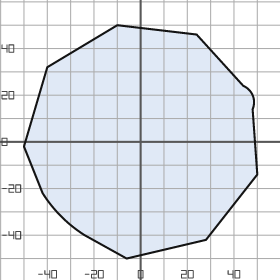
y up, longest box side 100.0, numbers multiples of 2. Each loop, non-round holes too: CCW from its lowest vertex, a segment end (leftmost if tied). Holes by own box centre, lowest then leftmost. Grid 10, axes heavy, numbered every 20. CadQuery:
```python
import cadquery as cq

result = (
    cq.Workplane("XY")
    .moveTo(-6.0, -50.0)
    .lineTo(28.0, -42.0)
    .lineTo(50.0, -14.0)
    .lineTo(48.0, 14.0)
    .threePointArc((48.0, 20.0), (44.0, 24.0))
    .lineTo(24.0, 46.0)
    .lineTo(-10.0, 50.0)
    .lineTo(-40.0, 32.0)
    .lineTo(-50.0, -2.0)
    .lineTo(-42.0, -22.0)
    .threePointArc((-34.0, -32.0), (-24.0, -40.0))
    .close()
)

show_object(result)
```